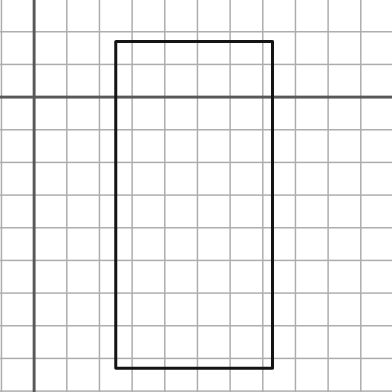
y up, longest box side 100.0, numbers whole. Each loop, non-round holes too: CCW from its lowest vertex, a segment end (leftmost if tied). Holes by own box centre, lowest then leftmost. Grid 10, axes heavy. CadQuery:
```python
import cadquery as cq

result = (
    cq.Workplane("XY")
    .moveTo(25.0, -83.0)
    .lineTo(73.0, -83.0)
    .lineTo(73.0, 17.0)
    .lineTo(25.0, 17.0)
    .close()
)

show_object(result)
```